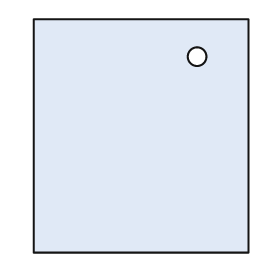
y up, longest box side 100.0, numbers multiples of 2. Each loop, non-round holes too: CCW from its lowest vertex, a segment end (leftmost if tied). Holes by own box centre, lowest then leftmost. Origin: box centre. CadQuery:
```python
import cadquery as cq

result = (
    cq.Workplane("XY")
    .moveTo(-46.0, -50.0)
    .lineTo(46.0, -50.0)
    .lineTo(46.0, 50.0)
    .lineTo(-46.0, 50.0)
    .close()
    .moveTo(24.0, 34.0)
    .circle(4.0)
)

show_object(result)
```